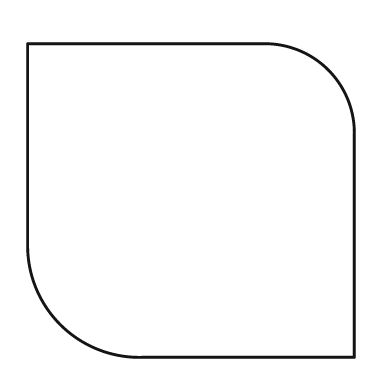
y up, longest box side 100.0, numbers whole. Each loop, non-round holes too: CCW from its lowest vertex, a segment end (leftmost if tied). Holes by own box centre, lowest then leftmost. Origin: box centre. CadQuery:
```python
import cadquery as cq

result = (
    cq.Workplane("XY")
    .moveTo(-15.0, -48.0)
    .lineTo(50.0, -48.0)
    .lineTo(50.0, 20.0)
    .threePointArc((42.0, 40.0), (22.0, 48.0))
    .lineTo(-50.0, 48.0)
    .lineTo(-50.0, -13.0)
    .threePointArc((-40.0, -38.0), (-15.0, -48.0))
    .close()
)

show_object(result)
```